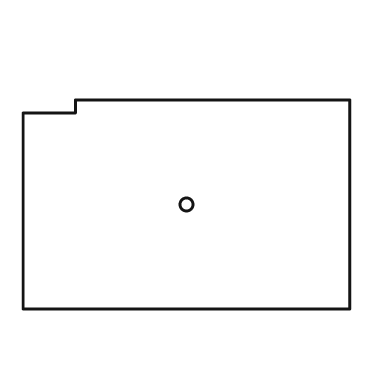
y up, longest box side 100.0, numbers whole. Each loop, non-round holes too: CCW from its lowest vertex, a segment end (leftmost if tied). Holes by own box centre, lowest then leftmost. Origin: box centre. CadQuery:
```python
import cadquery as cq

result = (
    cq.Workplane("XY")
    .moveTo(-50.0, -32.0)
    .lineTo(50.0, -32.0)
    .lineTo(50.0, 32.0)
    .lineTo(-34.0, 32.0)
    .lineTo(-34.0, 28.0)
    .lineTo(-50.0, 28.0)
    .close()
    .moveTo(0.0, 0.0)
    .circle(2.0)
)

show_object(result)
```